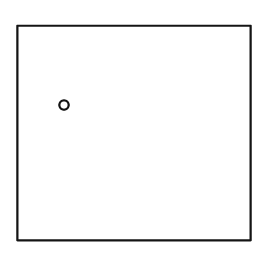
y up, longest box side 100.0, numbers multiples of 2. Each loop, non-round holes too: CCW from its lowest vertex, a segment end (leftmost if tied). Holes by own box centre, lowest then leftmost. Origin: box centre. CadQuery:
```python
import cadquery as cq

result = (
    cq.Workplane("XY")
    .moveTo(-50.0, -46.0)
    .lineTo(50.0, -46.0)
    .lineTo(50.0, 46.0)
    .lineTo(-50.0, 46.0)
    .close()
    .moveTo(-30.0, 12.0)
    .circle(2.0)
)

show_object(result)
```